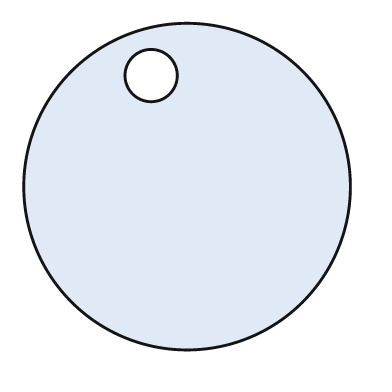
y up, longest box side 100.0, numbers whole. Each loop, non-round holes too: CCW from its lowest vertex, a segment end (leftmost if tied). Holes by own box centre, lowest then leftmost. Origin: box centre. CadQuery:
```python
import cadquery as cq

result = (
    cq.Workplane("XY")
    .moveTo(0.0, 0.0)
    .circle(50.0)
    .moveTo(-11.0, 34.0)
    .circle(8.0)
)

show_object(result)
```